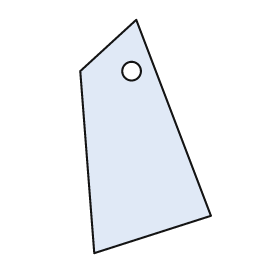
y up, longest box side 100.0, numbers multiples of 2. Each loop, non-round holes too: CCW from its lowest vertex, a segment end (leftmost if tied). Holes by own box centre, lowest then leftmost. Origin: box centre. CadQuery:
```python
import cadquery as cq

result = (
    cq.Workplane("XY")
    .moveTo(-22.0, -50.0)
    .lineTo(28.0, -34.0)
    .lineTo(-4.0, 50.0)
    .lineTo(-28.0, 28.0)
    .close()
    .moveTo(-6.0, 28.0)
    .circle(4.0)
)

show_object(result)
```